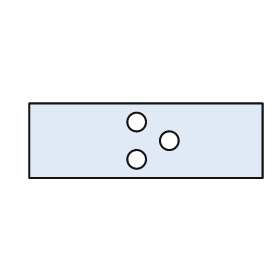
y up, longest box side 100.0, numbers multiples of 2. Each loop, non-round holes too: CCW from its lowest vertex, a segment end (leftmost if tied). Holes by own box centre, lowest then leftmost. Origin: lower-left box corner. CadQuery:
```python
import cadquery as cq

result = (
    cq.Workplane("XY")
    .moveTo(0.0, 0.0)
    .lineTo(100.0, 0.0)
    .lineTo(100.0, 32.0)
    .lineTo(0.0, 32.0)
    .close()
    .moveTo(46.0, 8.0)
    .circle(4.0)
    .moveTo(60.0, 16.0)
    .circle(4.0)
    .moveTo(46.0, 24.0)
    .circle(4.0)
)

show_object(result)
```